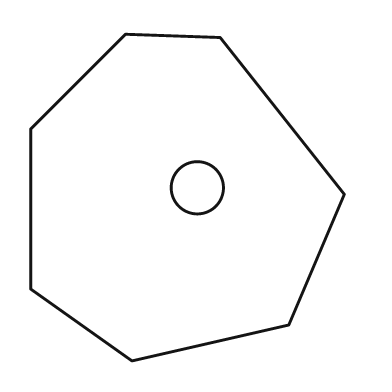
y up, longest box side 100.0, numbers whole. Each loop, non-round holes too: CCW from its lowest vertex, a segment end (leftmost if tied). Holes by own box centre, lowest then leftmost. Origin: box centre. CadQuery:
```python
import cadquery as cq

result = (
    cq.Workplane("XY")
    .moveTo(-17.0, -50.0)
    .lineTo(31.0, -39.0)
    .lineTo(48.0, 1.0)
    .lineTo(10.0, 49.0)
    .lineTo(-19.0, 50.0)
    .lineTo(-48.0, 21.0)
    .lineTo(-48.0, -28.0)
    .close()
    .moveTo(3.0, 3.0)
    .circle(8.0)
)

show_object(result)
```